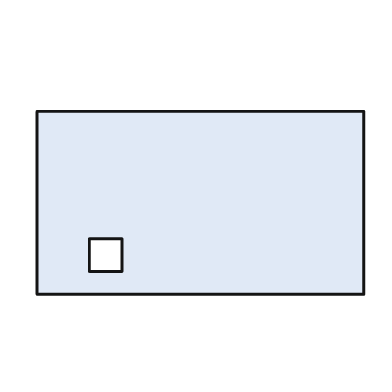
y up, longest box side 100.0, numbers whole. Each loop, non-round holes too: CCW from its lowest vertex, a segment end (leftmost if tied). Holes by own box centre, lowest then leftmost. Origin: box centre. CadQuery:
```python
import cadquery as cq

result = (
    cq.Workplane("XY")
    .moveTo(-50.0, -28.0)
    .lineTo(50.0, -28.0)
    .lineTo(50.0, 28.0)
    .lineTo(-50.0, 28.0)
    .close()
    .moveTo(-34.0, -21.0)
    .lineTo(-24.0, -21.0)
    .lineTo(-24.0, -11.0)
    .lineTo(-34.0, -11.0)
    .close()
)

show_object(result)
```